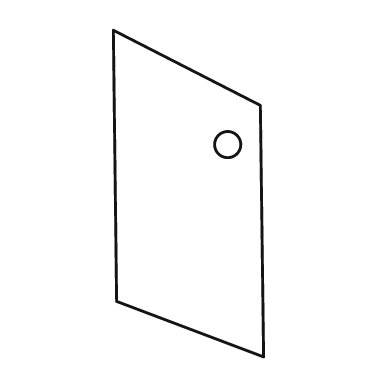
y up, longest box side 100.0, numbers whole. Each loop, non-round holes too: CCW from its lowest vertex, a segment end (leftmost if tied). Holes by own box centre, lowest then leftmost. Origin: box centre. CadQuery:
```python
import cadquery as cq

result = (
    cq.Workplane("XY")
    .moveTo(23.0, -50.0)
    .lineTo(22.0, 27.0)
    .lineTo(-23.0, 50.0)
    .lineTo(-22.0, -33.0)
    .close()
    .moveTo(12.0, 15.0)
    .circle(4.0)
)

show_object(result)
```